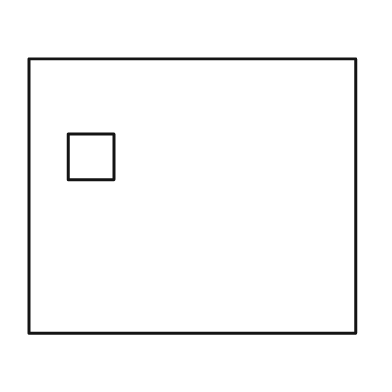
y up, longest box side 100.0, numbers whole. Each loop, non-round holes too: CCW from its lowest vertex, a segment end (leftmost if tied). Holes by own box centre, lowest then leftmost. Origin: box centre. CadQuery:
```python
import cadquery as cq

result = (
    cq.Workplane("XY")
    .moveTo(-50.0, -42.0)
    .lineTo(50.0, -42.0)
    .lineTo(50.0, 42.0)
    .lineTo(-50.0, 42.0)
    .close()
    .moveTo(-38.0, 5.0)
    .lineTo(-24.0, 5.0)
    .lineTo(-24.0, 19.0)
    .lineTo(-38.0, 19.0)
    .close()
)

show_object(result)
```